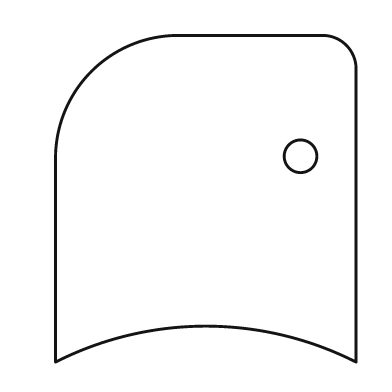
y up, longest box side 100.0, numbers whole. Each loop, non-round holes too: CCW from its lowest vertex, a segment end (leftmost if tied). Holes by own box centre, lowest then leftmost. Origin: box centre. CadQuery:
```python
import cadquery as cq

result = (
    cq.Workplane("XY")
    .moveTo(-46.0, -50.0)
    .threePointArc((0.0, -39.0), (46.0, -50.0))
    .lineTo(46.0, 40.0)
    .threePointArc((43.0, 47.0), (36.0, 50.0))
    .lineTo(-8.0, 50.0)
    .threePointArc((-35.0, 39.0), (-46.0, 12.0))
    .close()
    .moveTo(29.0, 13.0)
    .circle(5.0)
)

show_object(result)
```